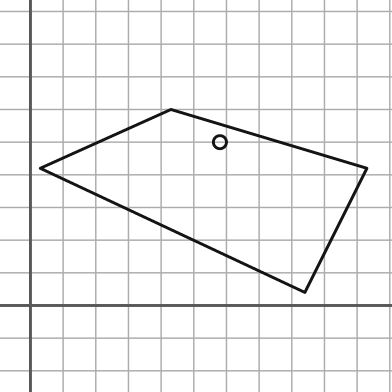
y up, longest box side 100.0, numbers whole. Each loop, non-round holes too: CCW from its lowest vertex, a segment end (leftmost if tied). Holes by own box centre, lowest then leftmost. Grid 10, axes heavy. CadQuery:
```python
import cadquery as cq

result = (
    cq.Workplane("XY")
    .moveTo(84.0, 4.0)
    .lineTo(103.0, 42.0)
    .lineTo(43.0, 60.0)
    .lineTo(3.0, 42.0)
    .close()
    .moveTo(58.0, 50.0)
    .circle(2.0)
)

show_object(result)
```